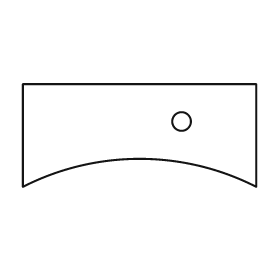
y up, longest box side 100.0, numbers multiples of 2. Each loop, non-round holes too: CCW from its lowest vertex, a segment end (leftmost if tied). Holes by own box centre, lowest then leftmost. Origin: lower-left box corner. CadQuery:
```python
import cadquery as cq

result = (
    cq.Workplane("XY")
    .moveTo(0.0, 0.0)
    .threePointArc((50.0, 12.0), (100.0, 0.0))
    .lineTo(100.0, 44.0)
    .lineTo(0.0, 44.0)
    .close()
    .moveTo(68.0, 28.0)
    .circle(4.0)
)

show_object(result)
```